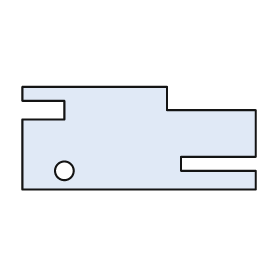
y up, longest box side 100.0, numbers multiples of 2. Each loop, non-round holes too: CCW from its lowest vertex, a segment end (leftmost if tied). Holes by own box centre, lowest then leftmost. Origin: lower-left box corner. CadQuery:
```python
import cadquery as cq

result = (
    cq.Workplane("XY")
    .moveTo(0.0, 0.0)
    .lineTo(100.0, 0.0)
    .lineTo(100.0, 8.0)
    .lineTo(68.0, 8.0)
    .lineTo(68.0, 14.0)
    .lineTo(100.0, 14.0)
    .lineTo(100.0, 34.0)
    .lineTo(62.0, 34.0)
    .lineTo(62.0, 44.0)
    .lineTo(0.0, 44.0)
    .lineTo(0.0, 38.0)
    .lineTo(18.0, 38.0)
    .lineTo(18.0, 30.0)
    .lineTo(0.0, 30.0)
    .close()
    .moveTo(18.0, 8.0)
    .circle(4.0)
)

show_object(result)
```